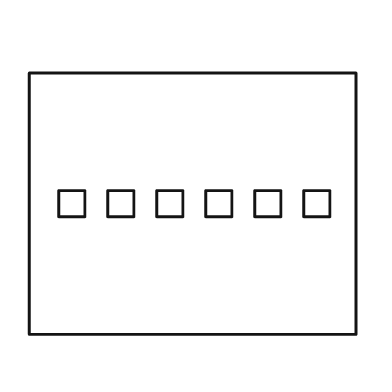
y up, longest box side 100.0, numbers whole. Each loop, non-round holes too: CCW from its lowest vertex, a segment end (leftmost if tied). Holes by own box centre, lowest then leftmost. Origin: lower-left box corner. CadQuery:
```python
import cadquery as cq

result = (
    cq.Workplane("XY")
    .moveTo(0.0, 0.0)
    .lineTo(100.0, 0.0)
    .lineTo(100.0, 80.0)
    .lineTo(0.0, 80.0)
    .close()
    .moveTo(9.0, 36.0)
    .lineTo(17.0, 36.0)
    .lineTo(17.0, 44.0)
    .lineTo(9.0, 44.0)
    .close()
    .moveTo(24.0, 36.0)
    .lineTo(32.0, 36.0)
    .lineTo(32.0, 44.0)
    .lineTo(24.0, 44.0)
    .close()
    .moveTo(39.0, 36.0)
    .lineTo(47.0, 36.0)
    .lineTo(47.0, 44.0)
    .lineTo(39.0, 44.0)
    .close()
    .moveTo(54.0, 36.0)
    .lineTo(62.0, 36.0)
    .lineTo(62.0, 44.0)
    .lineTo(54.0, 44.0)
    .close()
    .moveTo(69.0, 36.0)
    .lineTo(77.0, 36.0)
    .lineTo(77.0, 44.0)
    .lineTo(69.0, 44.0)
    .close()
    .moveTo(84.0, 36.0)
    .lineTo(92.0, 36.0)
    .lineTo(92.0, 44.0)
    .lineTo(84.0, 44.0)
    .close()
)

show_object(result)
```